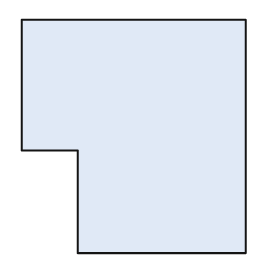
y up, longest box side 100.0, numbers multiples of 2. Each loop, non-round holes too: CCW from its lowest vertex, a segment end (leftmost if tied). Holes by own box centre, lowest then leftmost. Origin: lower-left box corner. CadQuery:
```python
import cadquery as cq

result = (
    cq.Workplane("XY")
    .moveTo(24.0, 0.0)
    .lineTo(96.0, 0.0)
    .lineTo(96.0, 100.0)
    .lineTo(0.0, 100.0)
    .lineTo(0.0, 44.0)
    .lineTo(24.0, 44.0)
    .close()
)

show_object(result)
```